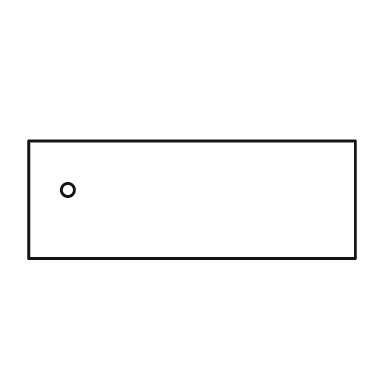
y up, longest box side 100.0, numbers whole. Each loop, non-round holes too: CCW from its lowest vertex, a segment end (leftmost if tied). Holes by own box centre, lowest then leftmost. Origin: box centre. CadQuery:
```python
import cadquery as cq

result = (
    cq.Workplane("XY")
    .moveTo(-50.0, -18.0)
    .lineTo(50.0, -18.0)
    .lineTo(50.0, 18.0)
    .lineTo(-50.0, 18.0)
    .close()
    .moveTo(-38.0, 3.0)
    .circle(2.0)
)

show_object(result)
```